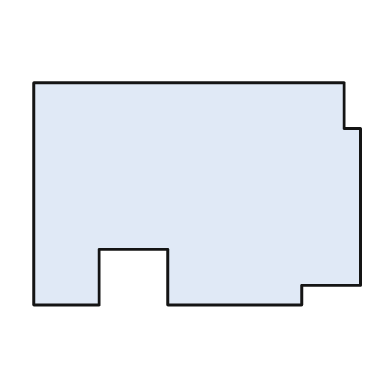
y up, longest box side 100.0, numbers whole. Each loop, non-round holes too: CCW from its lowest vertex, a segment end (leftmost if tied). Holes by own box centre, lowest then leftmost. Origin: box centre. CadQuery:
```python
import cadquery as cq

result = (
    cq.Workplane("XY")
    .moveTo(-50.0, -34.0)
    .lineTo(-30.0, -34.0)
    .lineTo(-30.0, -17.0)
    .lineTo(-9.0, -17.0)
    .lineTo(-9.0, -34.0)
    .lineTo(32.0, -34.0)
    .lineTo(32.0, -28.0)
    .lineTo(50.0, -28.0)
    .lineTo(50.0, 20.0)
    .lineTo(45.0, 20.0)
    .lineTo(45.0, 34.0)
    .lineTo(-50.0, 34.0)
    .close()
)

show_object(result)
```